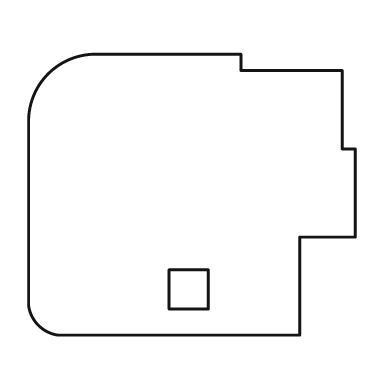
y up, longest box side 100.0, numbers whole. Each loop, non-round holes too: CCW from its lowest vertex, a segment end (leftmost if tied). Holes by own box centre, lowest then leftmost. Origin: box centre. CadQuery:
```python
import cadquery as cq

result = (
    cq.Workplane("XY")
    .moveTo(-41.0, -43.0)
    .lineTo(33.0, -43.0)
    .lineTo(33.0, -13.0)
    .lineTo(50.0, -13.0)
    .lineTo(50.0, 14.0)
    .lineTo(46.0, 14.0)
    .lineTo(46.0, 38.0)
    .lineTo(15.0, 38.0)
    .lineTo(15.0, 43.0)
    .lineTo(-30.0, 43.0)
    .threePointArc((-44.0, 37.0), (-50.0, 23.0))
    .lineTo(-50.0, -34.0)
    .threePointArc((-47.0, -40.0), (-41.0, -43.0))
    .close()
    .moveTo(-7.0, -35.0)
    .lineTo(5.0, -35.0)
    .lineTo(5.0, -23.0)
    .lineTo(-7.0, -23.0)
    .close()
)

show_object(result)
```